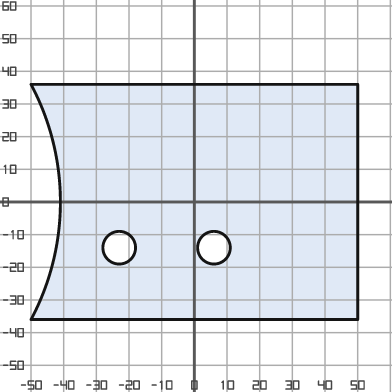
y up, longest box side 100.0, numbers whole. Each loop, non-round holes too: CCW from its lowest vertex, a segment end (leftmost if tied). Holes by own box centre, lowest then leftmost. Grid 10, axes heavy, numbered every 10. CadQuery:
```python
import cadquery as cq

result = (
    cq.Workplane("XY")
    .moveTo(-50.0, -36.0)
    .lineTo(50.0, -36.0)
    .lineTo(50.0, 36.0)
    .lineTo(-50.0, 36.0)
    .threePointArc((-41.0, 0.0), (-50.0, -36.0))
    .close()
    .moveTo(-23.0, -14.0)
    .circle(5.0)
    .moveTo(6.0, -14.0)
    .circle(5.0)
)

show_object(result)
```